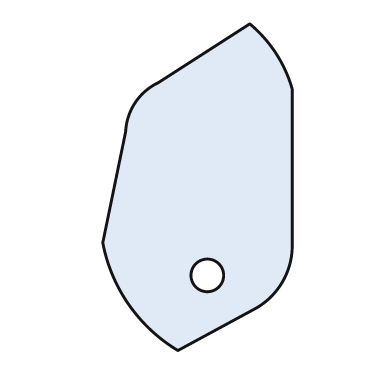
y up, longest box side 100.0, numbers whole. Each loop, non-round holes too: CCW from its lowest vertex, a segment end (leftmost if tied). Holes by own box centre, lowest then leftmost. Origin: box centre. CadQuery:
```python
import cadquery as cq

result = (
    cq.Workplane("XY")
    .moveTo(-6.0, -50.0)
    .lineTo(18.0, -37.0)
    .threePointArc((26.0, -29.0), (29.0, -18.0))
    .lineTo(29.0, 30.0)
    .threePointArc((24.0, 41.0), (16.0, 50.0))
    .lineTo(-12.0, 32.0)
    .threePointArc((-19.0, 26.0), (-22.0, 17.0))
    .lineTo(-29.0, -17.0)
    .threePointArc((-21.0, -36.0), (-6.0, -50.0))
    .close()
    .moveTo(3.0, -27.0)
    .circle(5.0)
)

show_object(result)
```